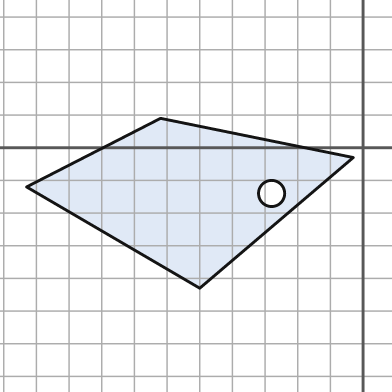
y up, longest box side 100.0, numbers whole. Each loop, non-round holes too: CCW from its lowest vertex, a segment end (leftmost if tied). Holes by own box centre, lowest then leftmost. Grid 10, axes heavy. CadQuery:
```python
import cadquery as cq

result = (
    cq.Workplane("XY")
    .moveTo(-50.0, -43.0)
    .lineTo(-3.0, -3.0)
    .lineTo(-62.0, 9.0)
    .lineTo(-103.0, -12.0)
    .close()
    .moveTo(-28.0, -14.0)
    .circle(4.0)
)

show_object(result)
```